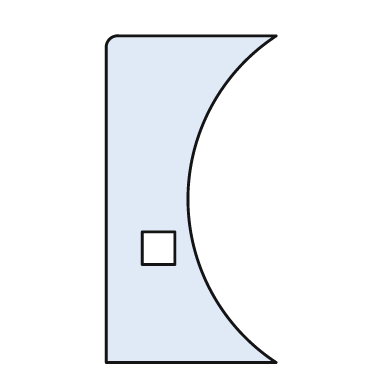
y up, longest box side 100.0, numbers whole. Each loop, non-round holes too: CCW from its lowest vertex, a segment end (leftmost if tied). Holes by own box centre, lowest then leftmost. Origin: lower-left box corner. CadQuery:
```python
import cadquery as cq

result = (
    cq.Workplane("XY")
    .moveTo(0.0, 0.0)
    .lineTo(52.0, 0.0)
    .threePointArc((25.0, 50.0), (52.0, 100.0))
    .lineTo(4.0, 100.0)
    .threePointArc((1.0, 99.0), (0.0, 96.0))
    .close()
    .moveTo(11.0, 30.0)
    .lineTo(21.0, 30.0)
    .lineTo(21.0, 40.0)
    .lineTo(11.0, 40.0)
    .close()
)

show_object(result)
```